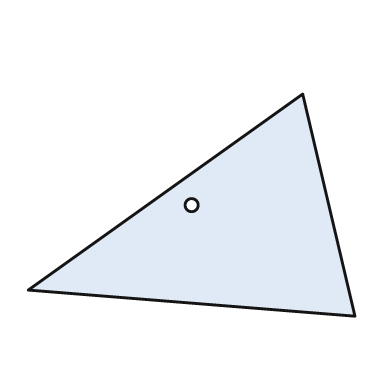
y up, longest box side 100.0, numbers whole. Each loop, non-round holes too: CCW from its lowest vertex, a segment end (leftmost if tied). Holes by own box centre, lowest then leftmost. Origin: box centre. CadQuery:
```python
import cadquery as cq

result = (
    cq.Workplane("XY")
    .moveTo(50.0, -34.0)
    .lineTo(34.0, 34.0)
    .lineTo(-50.0, -26.0)
    .close()
    .moveTo(0.0, 0.0)
    .circle(2.0)
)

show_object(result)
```